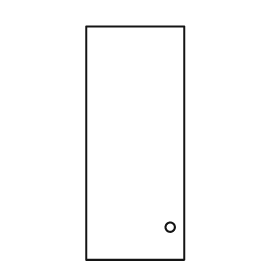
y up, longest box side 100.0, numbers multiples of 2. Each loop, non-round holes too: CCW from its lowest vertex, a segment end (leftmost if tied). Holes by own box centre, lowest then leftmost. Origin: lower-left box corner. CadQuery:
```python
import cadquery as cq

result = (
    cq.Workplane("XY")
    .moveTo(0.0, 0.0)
    .lineTo(42.0, 0.0)
    .lineTo(42.0, 100.0)
    .lineTo(0.0, 100.0)
    .close()
    .moveTo(36.0, 14.0)
    .circle(2.0)
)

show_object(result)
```